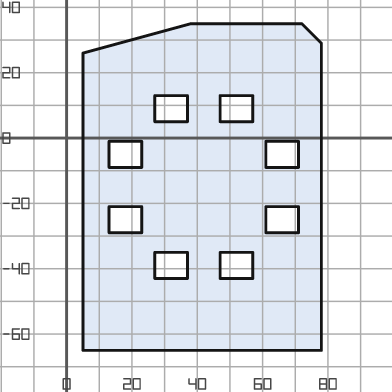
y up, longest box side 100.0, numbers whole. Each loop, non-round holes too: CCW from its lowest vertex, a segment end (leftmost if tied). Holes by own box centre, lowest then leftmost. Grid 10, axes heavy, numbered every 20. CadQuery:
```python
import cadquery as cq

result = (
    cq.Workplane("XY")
    .moveTo(5.0, -65.0)
    .lineTo(78.0, -65.0)
    .lineTo(78.0, 29.0)
    .lineTo(72.0, 35.0)
    .lineTo(38.0, 35.0)
    .lineTo(5.0, 26.0)
    .close()
    .moveTo(27.0, -43.0)
    .lineTo(37.0, -43.0)
    .lineTo(37.0, -35.0)
    .lineTo(27.0, -35.0)
    .close()
    .moveTo(47.0, -43.0)
    .lineTo(57.0, -43.0)
    .lineTo(57.0, -35.0)
    .lineTo(47.0, -35.0)
    .close()
    .moveTo(13.0, -29.0)
    .lineTo(23.0, -29.0)
    .lineTo(23.0, -21.0)
    .lineTo(13.0, -21.0)
    .close()
    .moveTo(61.0, -29.0)
    .lineTo(71.0, -29.0)
    .lineTo(71.0, -21.0)
    .lineTo(61.0, -21.0)
    .close()
    .moveTo(13.0, -9.0)
    .lineTo(23.0, -9.0)
    .lineTo(23.0, -1.0)
    .lineTo(13.0, -1.0)
    .close()
    .moveTo(61.0, -9.0)
    .lineTo(71.0, -9.0)
    .lineTo(71.0, -1.0)
    .lineTo(61.0, -1.0)
    .close()
    .moveTo(27.0, 5.0)
    .lineTo(37.0, 5.0)
    .lineTo(37.0, 13.0)
    .lineTo(27.0, 13.0)
    .close()
    .moveTo(47.0, 5.0)
    .lineTo(57.0, 5.0)
    .lineTo(57.0, 13.0)
    .lineTo(47.0, 13.0)
    .close()
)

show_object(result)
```